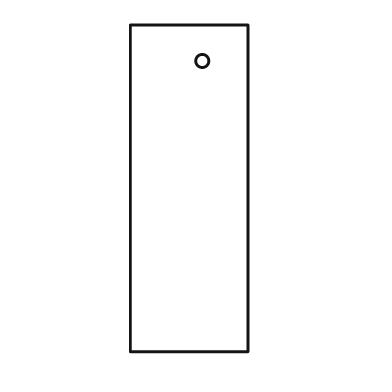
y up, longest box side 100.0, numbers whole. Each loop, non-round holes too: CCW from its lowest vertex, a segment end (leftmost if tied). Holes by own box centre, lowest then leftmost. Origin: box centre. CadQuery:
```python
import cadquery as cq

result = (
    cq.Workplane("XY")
    .moveTo(-18.0, -50.0)
    .lineTo(18.0, -50.0)
    .lineTo(18.0, 50.0)
    .lineTo(-18.0, 50.0)
    .close()
    .moveTo(4.0, 39.0)
    .circle(2.0)
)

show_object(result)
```